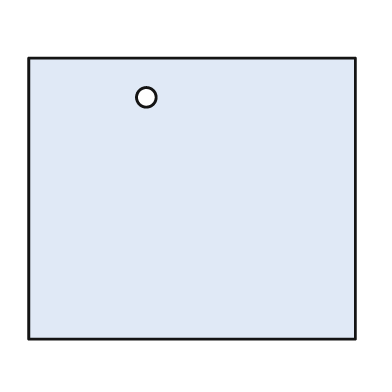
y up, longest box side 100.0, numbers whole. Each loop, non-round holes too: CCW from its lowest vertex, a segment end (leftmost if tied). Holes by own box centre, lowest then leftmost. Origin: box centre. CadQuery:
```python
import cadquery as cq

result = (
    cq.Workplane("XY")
    .moveTo(-50.0, -43.0)
    .lineTo(50.0, -43.0)
    .lineTo(50.0, 43.0)
    .lineTo(-50.0, 43.0)
    .close()
    .moveTo(-14.0, 31.0)
    .circle(3.0)
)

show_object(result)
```